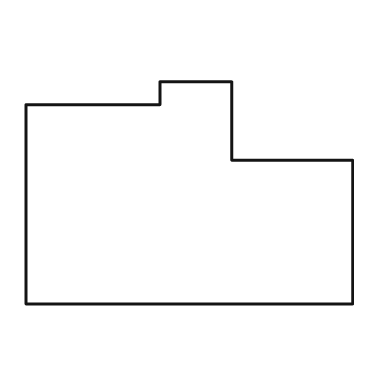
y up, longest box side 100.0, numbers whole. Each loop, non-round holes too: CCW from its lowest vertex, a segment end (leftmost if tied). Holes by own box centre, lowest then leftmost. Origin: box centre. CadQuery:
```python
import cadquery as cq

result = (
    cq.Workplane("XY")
    .moveTo(-50.0, -34.0)
    .lineTo(50.0, -34.0)
    .lineTo(50.0, 10.0)
    .lineTo(13.0, 10.0)
    .lineTo(13.0, 34.0)
    .lineTo(-9.0, 34.0)
    .lineTo(-9.0, 27.0)
    .lineTo(-50.0, 27.0)
    .close()
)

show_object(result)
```